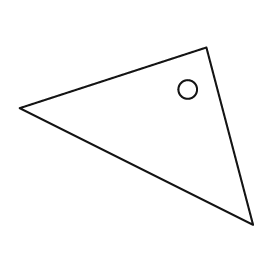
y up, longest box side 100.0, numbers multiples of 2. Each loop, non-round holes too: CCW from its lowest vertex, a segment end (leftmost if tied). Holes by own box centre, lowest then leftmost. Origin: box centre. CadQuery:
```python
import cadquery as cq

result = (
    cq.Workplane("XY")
    .moveTo(50.0, -38.0)
    .lineTo(30.0, 38.0)
    .lineTo(-50.0, 12.0)
    .close()
    .moveTo(22.0, 20.0)
    .circle(4.0)
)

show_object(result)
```